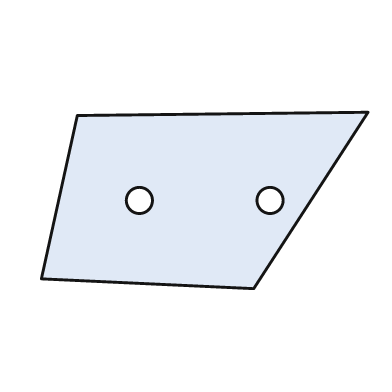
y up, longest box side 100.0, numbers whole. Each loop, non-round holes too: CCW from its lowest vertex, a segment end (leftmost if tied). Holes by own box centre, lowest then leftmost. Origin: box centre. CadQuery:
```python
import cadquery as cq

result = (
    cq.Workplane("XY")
    .moveTo(15.0, -27.0)
    .lineTo(50.0, 27.0)
    .lineTo(-39.0, 26.0)
    .lineTo(-50.0, -24.0)
    .close()
    .moveTo(-20.0, 0.0)
    .circle(4.0)
    .moveTo(20.0, 0.0)
    .circle(4.0)
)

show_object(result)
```